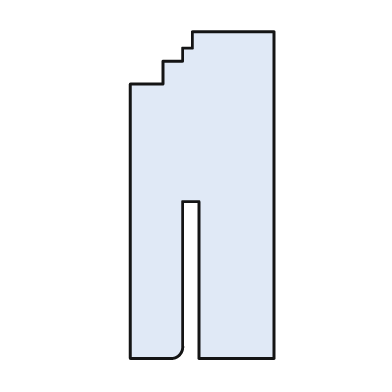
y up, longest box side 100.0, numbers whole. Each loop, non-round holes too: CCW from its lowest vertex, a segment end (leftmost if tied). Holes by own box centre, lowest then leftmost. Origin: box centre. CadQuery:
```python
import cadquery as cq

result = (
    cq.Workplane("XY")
    .moveTo(-22.0, -50.0)
    .lineTo(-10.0, -50.0)
    .threePointArc((-7.0, -49.0), (-6.0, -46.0))
    .lineTo(-6.0, -2.0)
    .lineTo(-1.0, -2.0)
    .lineTo(-1.0, -50.0)
    .lineTo(22.0, -50.0)
    .lineTo(22.0, 50.0)
    .lineTo(-3.0, 50.0)
    .lineTo(-3.0, 45.0)
    .lineTo(-6.0, 45.0)
    .lineTo(-6.0, 41.0)
    .lineTo(-12.0, 41.0)
    .lineTo(-12.0, 34.0)
    .lineTo(-22.0, 34.0)
    .close()
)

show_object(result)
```